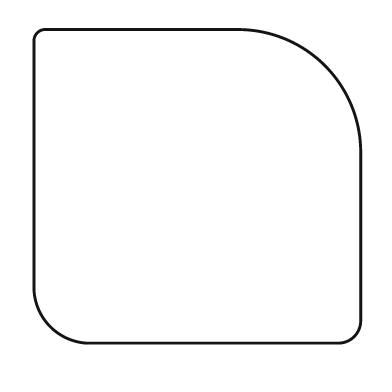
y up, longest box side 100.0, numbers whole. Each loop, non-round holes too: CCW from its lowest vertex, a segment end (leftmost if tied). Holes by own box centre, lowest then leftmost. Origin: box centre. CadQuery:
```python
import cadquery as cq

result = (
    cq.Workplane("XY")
    .moveTo(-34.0, -48.0)
    .lineTo(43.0, -48.0)
    .threePointArc((48.0, -46.0), (50.0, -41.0))
    .lineTo(50.0, 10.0)
    .threePointArc((39.0, 37.0), (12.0, 48.0))
    .lineTo(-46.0, 48.0)
    .threePointArc((-49.0, 47.0), (-50.0, 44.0))
    .lineTo(-50.0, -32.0)
    .threePointArc((-45.0, -43.0), (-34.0, -48.0))
    .close()
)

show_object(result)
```